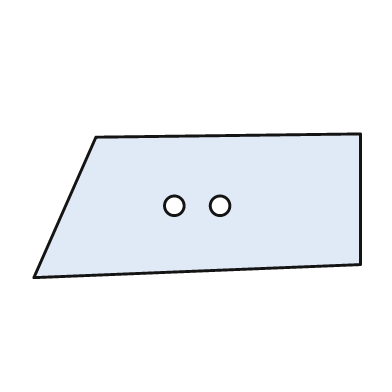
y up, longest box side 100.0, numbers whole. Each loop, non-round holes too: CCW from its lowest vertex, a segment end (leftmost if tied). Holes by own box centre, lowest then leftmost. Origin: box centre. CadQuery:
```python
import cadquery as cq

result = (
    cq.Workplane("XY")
    .moveTo(-50.0, -22.0)
    .lineTo(50.0, -18.0)
    .lineTo(50.0, 22.0)
    .lineTo(-31.0, 21.0)
    .close()
    .moveTo(-7.0, 0.0)
    .circle(3.0)
    .moveTo(7.0, 0.0)
    .circle(3.0)
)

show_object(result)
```